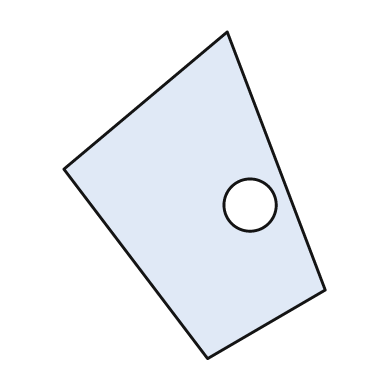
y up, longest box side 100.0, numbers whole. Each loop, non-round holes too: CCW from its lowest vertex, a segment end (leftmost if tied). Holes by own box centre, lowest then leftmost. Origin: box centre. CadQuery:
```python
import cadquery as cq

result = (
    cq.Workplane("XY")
    .moveTo(4.0, -50.0)
    .lineTo(40.0, -29.0)
    .lineTo(10.0, 50.0)
    .lineTo(-40.0, 8.0)
    .close()
    .moveTo(17.0, -3.0)
    .circle(8.0)
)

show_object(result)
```